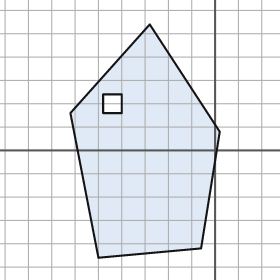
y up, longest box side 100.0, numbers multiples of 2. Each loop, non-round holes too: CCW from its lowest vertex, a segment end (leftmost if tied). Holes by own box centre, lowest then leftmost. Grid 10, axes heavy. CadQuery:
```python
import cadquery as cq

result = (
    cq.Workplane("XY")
    .moveTo(-50.0, -46.0)
    .lineTo(-6.0, -42.0)
    .lineTo(2.0, 8.0)
    .lineTo(-28.0, 54.0)
    .lineTo(-62.0, 16.0)
    .close()
    .moveTo(-48.0, 16.0)
    .lineTo(-40.0, 16.0)
    .lineTo(-40.0, 24.0)
    .lineTo(-48.0, 24.0)
    .close()
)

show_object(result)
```